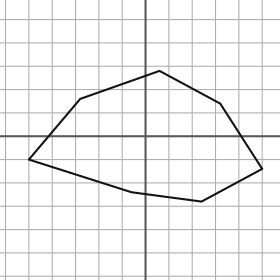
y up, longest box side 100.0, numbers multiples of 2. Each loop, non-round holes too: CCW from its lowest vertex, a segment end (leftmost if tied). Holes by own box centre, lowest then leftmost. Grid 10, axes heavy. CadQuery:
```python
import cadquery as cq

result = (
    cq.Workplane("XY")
    .moveTo(24.0, -28.0)
    .lineTo(50.0, -14.0)
    .lineTo(32.0, 14.0)
    .lineTo(6.0, 28.0)
    .lineTo(-28.0, 16.0)
    .lineTo(-50.0, -10.0)
    .lineTo(-6.0, -24.0)
    .close()
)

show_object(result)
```